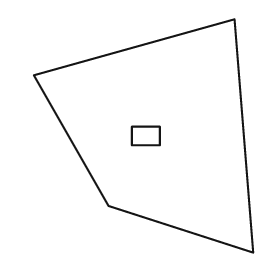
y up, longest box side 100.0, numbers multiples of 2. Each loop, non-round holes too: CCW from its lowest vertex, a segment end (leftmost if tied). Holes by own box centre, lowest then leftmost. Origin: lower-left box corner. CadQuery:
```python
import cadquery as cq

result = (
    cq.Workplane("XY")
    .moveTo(94.0, 0.0)
    .lineTo(86.0, 100.0)
    .lineTo(0.0, 76.0)
    .lineTo(32.0, 20.0)
    .close()
    .moveTo(42.0, 46.0)
    .lineTo(54.0, 46.0)
    .lineTo(54.0, 54.0)
    .lineTo(42.0, 54.0)
    .close()
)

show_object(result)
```